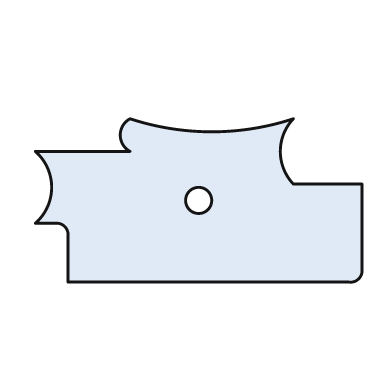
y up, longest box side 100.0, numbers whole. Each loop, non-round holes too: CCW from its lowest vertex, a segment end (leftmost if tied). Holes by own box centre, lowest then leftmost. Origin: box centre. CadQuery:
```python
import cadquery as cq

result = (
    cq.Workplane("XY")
    .moveTo(-40.0, -25.0)
    .lineTo(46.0, -25.0)
    .threePointArc((49.0, -24.0), (50.0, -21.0))
    .lineTo(50.0, 5.0)
    .lineTo(29.0, 5.0)
    .threePointArc((25.0, 15.0), (29.0, 25.0))
    .threePointArc((4.0, 21.0), (-21.0, 25.0))
    .threePointArc((-24.0, 20.0), (-21.0, 15.0))
    .lineTo(-50.0, 15.0)
    .threePointArc((-45.0, 4.0), (-50.0, -7.0))
    .lineTo(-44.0, -7.0)
    .threePointArc((-41.0, -8.0), (-40.0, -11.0))
    .close()
    .moveTo(0.0, 0.0)
    .circle(4.0)
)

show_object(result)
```